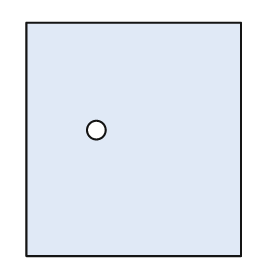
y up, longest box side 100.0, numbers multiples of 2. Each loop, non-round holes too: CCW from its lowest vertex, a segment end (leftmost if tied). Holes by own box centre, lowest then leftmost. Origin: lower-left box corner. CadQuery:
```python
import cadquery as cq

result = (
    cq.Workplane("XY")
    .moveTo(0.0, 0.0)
    .lineTo(92.0, 0.0)
    .lineTo(92.0, 100.0)
    .lineTo(0.0, 100.0)
    .close()
    .moveTo(30.0, 54.0)
    .circle(4.0)
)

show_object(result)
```